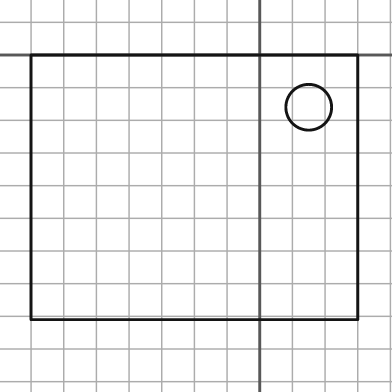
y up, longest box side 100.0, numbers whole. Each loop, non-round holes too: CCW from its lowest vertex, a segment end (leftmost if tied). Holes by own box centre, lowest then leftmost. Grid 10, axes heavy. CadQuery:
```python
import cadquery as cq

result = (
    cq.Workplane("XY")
    .moveTo(-70.0, -81.0)
    .lineTo(30.0, -81.0)
    .lineTo(30.0, 0.0)
    .lineTo(-70.0, 0.0)
    .close()
    .moveTo(15.0, -16.0)
    .circle(7.0)
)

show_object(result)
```